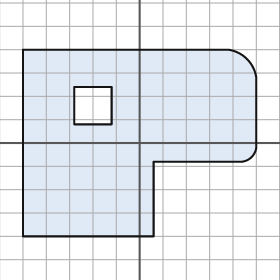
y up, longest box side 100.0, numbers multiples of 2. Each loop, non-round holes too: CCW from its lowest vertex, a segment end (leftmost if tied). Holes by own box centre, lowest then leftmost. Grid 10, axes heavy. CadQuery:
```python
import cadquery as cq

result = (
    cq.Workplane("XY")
    .moveTo(-50.0, -40.0)
    .lineTo(6.0, -40.0)
    .lineTo(6.0, -8.0)
    .lineTo(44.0, -8.0)
    .threePointArc((48.0, -6.0), (50.0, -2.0))
    .lineTo(50.0, 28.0)
    .threePointArc((46.0, 36.0), (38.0, 40.0))
    .lineTo(-50.0, 40.0)
    .close()
    .moveTo(-28.0, 8.0)
    .lineTo(-12.0, 8.0)
    .lineTo(-12.0, 24.0)
    .lineTo(-28.0, 24.0)
    .close()
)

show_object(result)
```